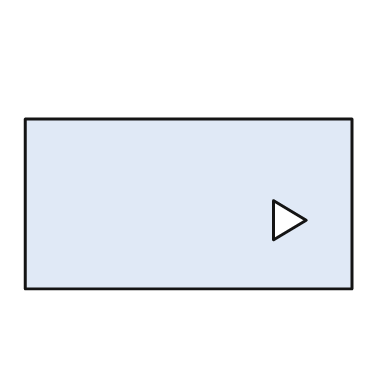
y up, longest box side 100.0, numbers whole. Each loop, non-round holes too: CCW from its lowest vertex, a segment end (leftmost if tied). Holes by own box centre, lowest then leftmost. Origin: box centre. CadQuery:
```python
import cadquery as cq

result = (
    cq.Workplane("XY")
    .moveTo(-50.0, -26.0)
    .lineTo(50.0, -26.0)
    .lineTo(50.0, 26.0)
    .lineTo(-50.0, 26.0)
    .close()
    .moveTo(26.0, -11.0)
    .lineTo(36.0, -5.0)
    .lineTo(26.0, 1.0)
    .close()
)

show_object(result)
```